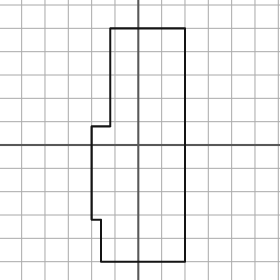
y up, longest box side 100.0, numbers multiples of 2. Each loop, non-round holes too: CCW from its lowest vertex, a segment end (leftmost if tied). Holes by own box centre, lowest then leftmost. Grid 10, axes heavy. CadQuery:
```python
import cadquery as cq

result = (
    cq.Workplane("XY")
    .moveTo(-16.0, -50.0)
    .lineTo(20.0, -50.0)
    .lineTo(20.0, 50.0)
    .lineTo(-12.0, 50.0)
    .lineTo(-12.0, 8.0)
    .lineTo(-20.0, 8.0)
    .lineTo(-20.0, -32.0)
    .lineTo(-16.0, -32.0)
    .close()
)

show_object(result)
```